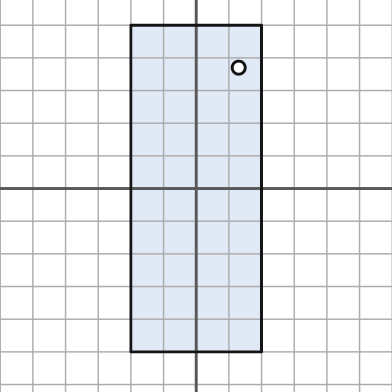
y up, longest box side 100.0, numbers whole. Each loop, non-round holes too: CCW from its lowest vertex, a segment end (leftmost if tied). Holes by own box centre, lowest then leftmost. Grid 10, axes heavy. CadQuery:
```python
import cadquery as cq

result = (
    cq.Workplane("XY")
    .moveTo(-20.0, -50.0)
    .lineTo(20.0, -50.0)
    .lineTo(20.0, 50.0)
    .lineTo(-20.0, 50.0)
    .close()
    .moveTo(13.0, 37.0)
    .circle(2.0)
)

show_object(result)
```